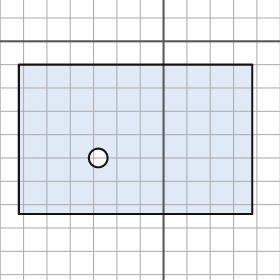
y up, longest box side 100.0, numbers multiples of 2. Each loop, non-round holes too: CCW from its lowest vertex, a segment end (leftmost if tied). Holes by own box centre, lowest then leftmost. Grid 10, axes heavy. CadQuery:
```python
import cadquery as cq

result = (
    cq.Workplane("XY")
    .moveTo(-62.0, -74.0)
    .lineTo(38.0, -74.0)
    .lineTo(38.0, -10.0)
    .lineTo(-62.0, -10.0)
    .close()
    .moveTo(-28.0, -50.0)
    .circle(4.0)
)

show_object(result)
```